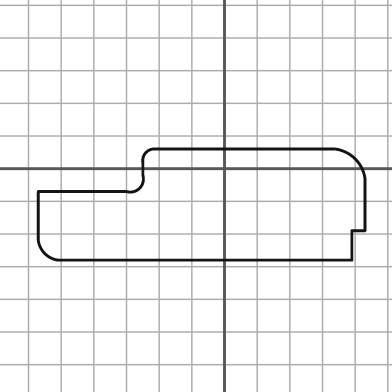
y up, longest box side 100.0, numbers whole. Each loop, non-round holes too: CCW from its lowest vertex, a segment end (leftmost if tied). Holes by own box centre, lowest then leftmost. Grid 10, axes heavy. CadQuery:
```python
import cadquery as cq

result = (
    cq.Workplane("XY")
    .moveTo(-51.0, -28.0)
    .lineTo(39.0, -28.0)
    .lineTo(39.0, -19.0)
    .lineTo(43.0, -19.0)
    .lineTo(43.0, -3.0)
    .threePointArc((40.0, 3.0), (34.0, 6.0))
    .lineTo(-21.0, 6.0)
    .threePointArc((-24.0, 5.0), (-25.0, 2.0))
    .lineTo(-25.0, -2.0)
    .threePointArc((-26.0, -6.0), (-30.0, -7.0))
    .lineTo(-57.0, -7.0)
    .lineTo(-57.0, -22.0)
    .threePointArc((-55.0, -26.0), (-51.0, -28.0))
    .close()
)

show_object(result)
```